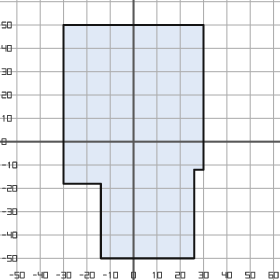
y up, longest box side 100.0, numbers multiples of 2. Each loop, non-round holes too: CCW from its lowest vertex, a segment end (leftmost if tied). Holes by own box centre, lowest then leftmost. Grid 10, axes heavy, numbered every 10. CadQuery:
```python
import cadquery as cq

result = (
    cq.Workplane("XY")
    .moveTo(-14.0, -50.0)
    .lineTo(26.0, -50.0)
    .lineTo(26.0, -12.0)
    .lineTo(30.0, -12.0)
    .lineTo(30.0, 50.0)
    .lineTo(-30.0, 50.0)
    .lineTo(-30.0, -18.0)
    .lineTo(-14.0, -18.0)
    .close()
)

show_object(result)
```